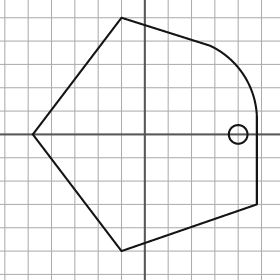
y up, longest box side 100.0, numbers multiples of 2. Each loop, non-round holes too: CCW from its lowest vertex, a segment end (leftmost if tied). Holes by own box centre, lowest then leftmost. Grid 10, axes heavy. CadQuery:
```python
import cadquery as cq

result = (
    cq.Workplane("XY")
    .moveTo(-10.0, -50.0)
    .lineTo(48.0, -30.0)
    .lineTo(48.0, 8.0)
    .threePointArc((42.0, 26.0), (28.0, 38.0))
    .lineTo(-10.0, 50.0)
    .lineTo(-48.0, 0.0)
    .close()
    .moveTo(40.0, 0.0)
    .circle(4.0)
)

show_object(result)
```